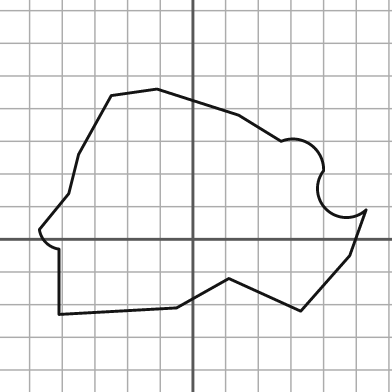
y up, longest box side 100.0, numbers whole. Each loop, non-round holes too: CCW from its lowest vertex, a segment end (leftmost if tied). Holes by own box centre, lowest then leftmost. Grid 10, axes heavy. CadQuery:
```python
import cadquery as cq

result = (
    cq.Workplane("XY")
    .moveTo(-41.0, -23.0)
    .lineTo(-5.0, -21.0)
    .lineTo(11.0, -12.0)
    .lineTo(33.0, -22.0)
    .lineTo(48.0, -5.0)
    .lineTo(53.0, 9.0)
    .threePointArc((41.0, 9.0), (40.0, 21.0))
    .threePointArc((36.0, 29.0), (27.0, 30.0))
    .lineTo(14.0, 38.0)
    .lineTo(-11.0, 46.0)
    .lineTo(-25.0, 44.0)
    .lineTo(-35.0, 26.0)
    .lineTo(-38.0, 14.0)
    .lineTo(-47.0, 3.0)
    .threePointArc((-45.0, -1.0), (-41.0, -3.0))
    .close()
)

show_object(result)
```